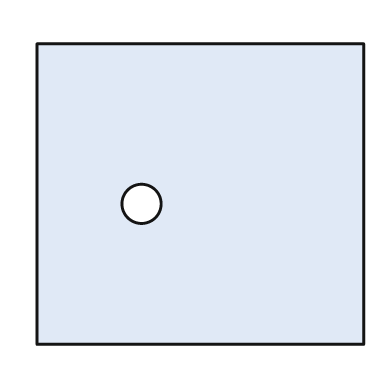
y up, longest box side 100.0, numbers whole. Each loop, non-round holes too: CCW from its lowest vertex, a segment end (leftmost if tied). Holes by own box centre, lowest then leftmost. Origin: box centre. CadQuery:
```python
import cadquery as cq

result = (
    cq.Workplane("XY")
    .moveTo(-50.0, -46.0)
    .lineTo(50.0, -46.0)
    .lineTo(50.0, 46.0)
    .lineTo(-50.0, 46.0)
    .close()
    .moveTo(-18.0, -3.0)
    .circle(6.0)
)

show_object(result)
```